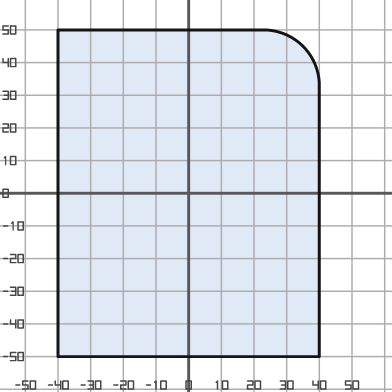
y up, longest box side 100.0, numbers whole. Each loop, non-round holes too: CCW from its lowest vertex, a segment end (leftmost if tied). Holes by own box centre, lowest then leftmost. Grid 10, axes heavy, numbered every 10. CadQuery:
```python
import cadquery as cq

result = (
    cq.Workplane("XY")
    .moveTo(-40.0, -50.0)
    .lineTo(40.0, -50.0)
    .lineTo(40.0, 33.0)
    .threePointArc((35.0, 45.0), (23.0, 50.0))
    .lineTo(-40.0, 50.0)
    .close()
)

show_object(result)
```